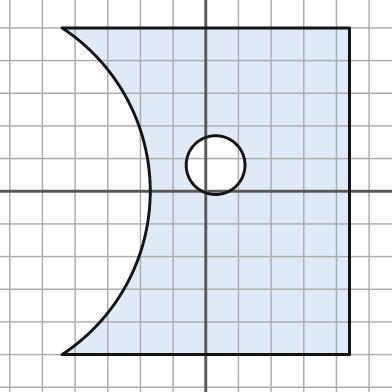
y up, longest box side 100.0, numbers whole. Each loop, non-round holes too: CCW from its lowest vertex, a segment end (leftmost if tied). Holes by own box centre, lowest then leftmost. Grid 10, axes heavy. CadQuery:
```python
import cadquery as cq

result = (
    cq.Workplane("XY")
    .moveTo(-44.0, -50.0)
    .lineTo(44.0, -50.0)
    .lineTo(44.0, 50.0)
    .lineTo(-44.0, 50.0)
    .threePointArc((-17.0, 0.0), (-44.0, -50.0))
    .close()
    .moveTo(3.0, 8.0)
    .circle(9.0)
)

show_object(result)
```